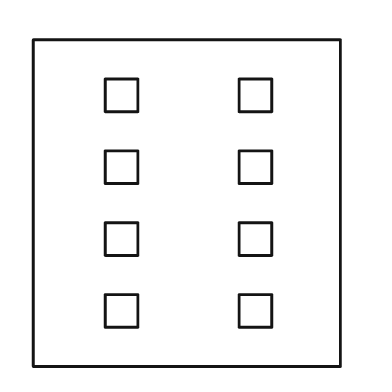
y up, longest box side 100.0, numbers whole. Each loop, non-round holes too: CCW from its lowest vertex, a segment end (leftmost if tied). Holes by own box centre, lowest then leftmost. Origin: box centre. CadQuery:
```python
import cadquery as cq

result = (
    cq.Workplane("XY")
    .moveTo(-47.0, -50.0)
    .lineTo(47.0, -50.0)
    .lineTo(47.0, 50.0)
    .lineTo(-47.0, 50.0)
    .close()
    .moveTo(-25.0, -38.0)
    .lineTo(-15.0, -38.0)
    .lineTo(-15.0, -28.0)
    .lineTo(-25.0, -28.0)
    .close()
    .moveTo(16.0, -38.0)
    .lineTo(26.0, -38.0)
    .lineTo(26.0, -28.0)
    .lineTo(16.0, -28.0)
    .close()
    .moveTo(-25.0, -16.0)
    .lineTo(-15.0, -16.0)
    .lineTo(-15.0, -6.0)
    .lineTo(-25.0, -6.0)
    .close()
    .moveTo(16.0, -16.0)
    .lineTo(26.0, -16.0)
    .lineTo(26.0, -6.0)
    .lineTo(16.0, -6.0)
    .close()
    .moveTo(-25.0, 6.0)
    .lineTo(-15.0, 6.0)
    .lineTo(-15.0, 16.0)
    .lineTo(-25.0, 16.0)
    .close()
    .moveTo(16.0, 6.0)
    .lineTo(26.0, 6.0)
    .lineTo(26.0, 16.0)
    .lineTo(16.0, 16.0)
    .close()
    .moveTo(-25.0, 28.0)
    .lineTo(-15.0, 28.0)
    .lineTo(-15.0, 38.0)
    .lineTo(-25.0, 38.0)
    .close()
    .moveTo(16.0, 28.0)
    .lineTo(26.0, 28.0)
    .lineTo(26.0, 38.0)
    .lineTo(16.0, 38.0)
    .close()
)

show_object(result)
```